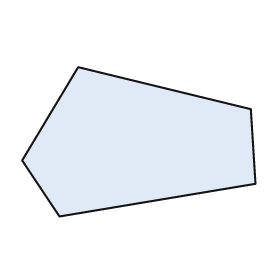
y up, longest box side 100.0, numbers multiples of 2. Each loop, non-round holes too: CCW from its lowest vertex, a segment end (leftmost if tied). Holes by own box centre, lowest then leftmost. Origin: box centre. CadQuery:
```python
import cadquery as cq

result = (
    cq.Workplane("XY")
    .moveTo(-34.0, -32.0)
    .lineTo(50.0, -18.0)
    .lineTo(48.0, 14.0)
    .lineTo(-26.0, 32.0)
    .lineTo(-50.0, -8.0)
    .close()
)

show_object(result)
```